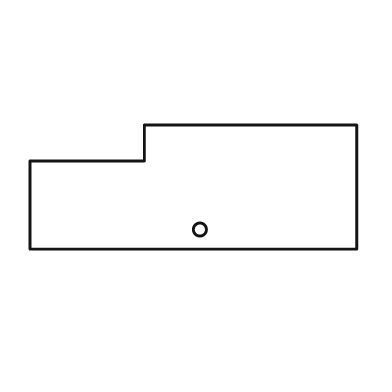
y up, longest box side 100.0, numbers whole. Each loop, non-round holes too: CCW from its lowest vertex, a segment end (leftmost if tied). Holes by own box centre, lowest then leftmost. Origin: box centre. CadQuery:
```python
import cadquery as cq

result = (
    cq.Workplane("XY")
    .moveTo(-50.0, -19.0)
    .lineTo(50.0, -19.0)
    .lineTo(50.0, 19.0)
    .lineTo(-15.0, 19.0)
    .lineTo(-15.0, 8.0)
    .lineTo(-50.0, 8.0)
    .close()
    .moveTo(2.0, -13.0)
    .circle(2.0)
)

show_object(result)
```